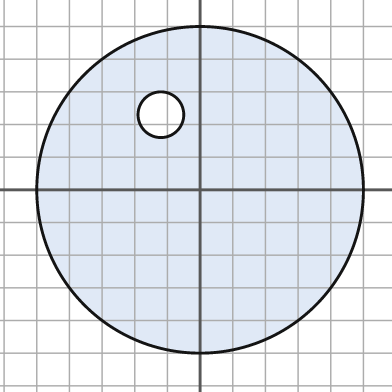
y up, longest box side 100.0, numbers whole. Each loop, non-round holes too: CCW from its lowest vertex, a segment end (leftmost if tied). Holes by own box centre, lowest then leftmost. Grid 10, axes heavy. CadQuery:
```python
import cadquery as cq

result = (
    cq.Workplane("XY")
    .moveTo(0.0, 0.0)
    .circle(50.0)
    .moveTo(-12.0, 23.0)
    .circle(7.0)
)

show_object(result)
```